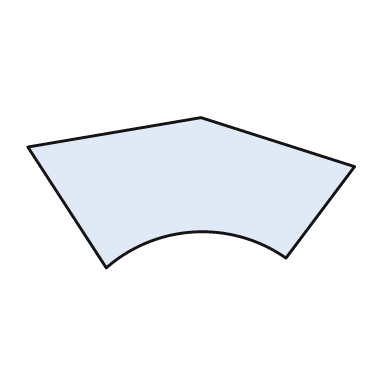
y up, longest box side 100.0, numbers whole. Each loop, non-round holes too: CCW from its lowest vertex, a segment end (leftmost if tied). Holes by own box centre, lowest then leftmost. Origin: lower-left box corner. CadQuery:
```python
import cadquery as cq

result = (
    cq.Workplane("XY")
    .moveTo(24.0, 0.0)
    .threePointArc((51.0, 11.0), (79.0, 3.0))
    .lineTo(100.0, 31.0)
    .lineTo(53.0, 46.0)
    .lineTo(0.0, 37.0)
    .close()
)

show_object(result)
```